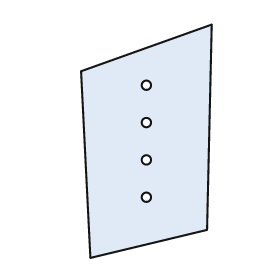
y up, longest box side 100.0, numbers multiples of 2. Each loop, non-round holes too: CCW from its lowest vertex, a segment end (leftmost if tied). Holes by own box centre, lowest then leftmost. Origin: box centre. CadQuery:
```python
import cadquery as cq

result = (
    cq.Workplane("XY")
    .moveTo(-24.0, -50.0)
    .lineTo(26.0, -38.0)
    .lineTo(28.0, 50.0)
    .lineTo(-28.0, 30.0)
    .close()
    .moveTo(0.0, -24.0)
    .circle(2.0)
    .moveTo(0.0, -8.0)
    .circle(2.0)
    .moveTo(0.0, 8.0)
    .circle(2.0)
    .moveTo(0.0, 24.0)
    .circle(2.0)
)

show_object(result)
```